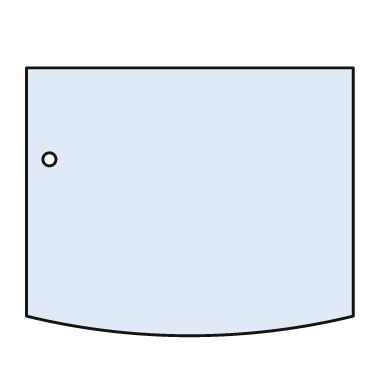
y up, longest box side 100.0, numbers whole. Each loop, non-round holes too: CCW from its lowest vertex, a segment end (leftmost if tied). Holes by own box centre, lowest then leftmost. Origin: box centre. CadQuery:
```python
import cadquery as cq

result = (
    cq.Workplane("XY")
    .moveTo(-50.0, -35.0)
    .threePointArc((0.0, -41.0), (50.0, -35.0))
    .lineTo(50.0, 41.0)
    .lineTo(-50.0, 41.0)
    .close()
    .moveTo(-43.0, 13.0)
    .circle(2.0)
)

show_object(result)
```